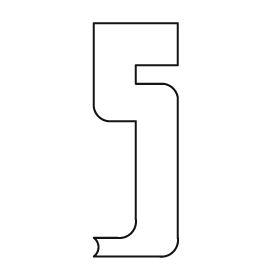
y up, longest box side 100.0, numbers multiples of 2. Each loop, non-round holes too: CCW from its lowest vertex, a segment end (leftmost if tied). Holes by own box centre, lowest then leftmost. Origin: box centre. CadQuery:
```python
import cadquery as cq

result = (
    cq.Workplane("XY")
    .moveTo(-18.0, -50.0)
    .lineTo(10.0, -50.0)
    .threePointArc((16.0, -48.0), (18.0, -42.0))
    .lineTo(18.0, 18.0)
    .threePointArc((16.0, 22.0), (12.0, 24.0))
    .lineTo(0.0, 24.0)
    .lineTo(0.0, 32.0)
    .lineTo(18.0, 32.0)
    .lineTo(18.0, 50.0)
    .lineTo(-18.0, 50.0)
    .lineTo(-18.0, 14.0)
    .threePointArc((-16.0, 10.0), (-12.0, 8.0))
    .lineTo(0.0, 8.0)
    .lineTo(0.0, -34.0)
    .threePointArc((-2.0, -40.0), (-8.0, -42.0))
    .lineTo(-18.0, -42.0)
    .threePointArc((-16.0, -46.0), (-18.0, -50.0))
    .close()
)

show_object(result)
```